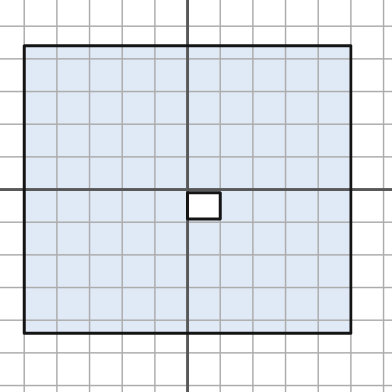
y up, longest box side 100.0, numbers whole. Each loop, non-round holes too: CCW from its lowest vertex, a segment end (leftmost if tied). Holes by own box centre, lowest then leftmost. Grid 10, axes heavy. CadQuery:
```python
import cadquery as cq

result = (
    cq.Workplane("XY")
    .moveTo(-50.0, -44.0)
    .lineTo(50.0, -44.0)
    .lineTo(50.0, 44.0)
    .lineTo(-50.0, 44.0)
    .close()
    .moveTo(0.0, -9.0)
    .lineTo(10.0, -9.0)
    .lineTo(10.0, -1.0)
    .lineTo(0.0, -1.0)
    .close()
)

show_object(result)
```